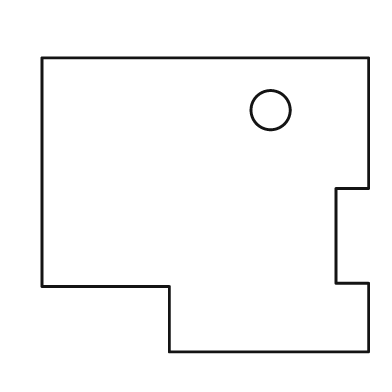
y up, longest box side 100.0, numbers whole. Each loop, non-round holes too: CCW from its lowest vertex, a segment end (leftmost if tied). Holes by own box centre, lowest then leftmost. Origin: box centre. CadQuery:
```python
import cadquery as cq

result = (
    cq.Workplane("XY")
    .moveTo(-11.0, -45.0)
    .lineTo(50.0, -45.0)
    .lineTo(50.0, -24.0)
    .lineTo(40.0, -24.0)
    .lineTo(40.0, 5.0)
    .lineTo(50.0, 5.0)
    .lineTo(50.0, 45.0)
    .lineTo(-50.0, 45.0)
    .lineTo(-50.0, -25.0)
    .lineTo(-11.0, -25.0)
    .close()
    .moveTo(20.0, 29.0)
    .circle(6.0)
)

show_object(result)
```